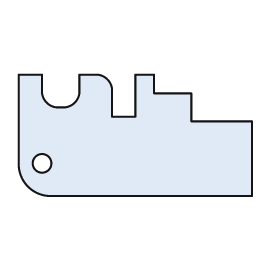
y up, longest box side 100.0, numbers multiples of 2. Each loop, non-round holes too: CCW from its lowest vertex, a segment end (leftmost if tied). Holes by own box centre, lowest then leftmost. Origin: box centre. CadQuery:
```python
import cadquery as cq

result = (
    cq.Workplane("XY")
    .moveTo(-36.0, -26.0)
    .lineTo(50.0, -26.0)
    .lineTo(50.0, 6.0)
    .lineTo(24.0, 6.0)
    .lineTo(24.0, 18.0)
    .lineTo(8.0, 18.0)
    .lineTo(8.0, 26.0)
    .lineTo(0.0, 26.0)
    .lineTo(0.0, 8.0)
    .lineTo(-10.0, 8.0)
    .lineTo(-10.0, 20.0)
    .threePointArc((-12.0, 24.0), (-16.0, 26.0))
    .lineTo(-24.0, 26.0)
    .lineTo(-24.0, 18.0)
    .threePointArc((-26.0, 14.0), (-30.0, 12.0))
    .lineTo(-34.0, 12.0)
    .threePointArc((-38.0, 14.0), (-40.0, 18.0))
    .lineTo(-40.0, 26.0)
    .lineTo(-50.0, 26.0)
    .lineTo(-50.0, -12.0)
    .threePointArc((-46.0, -22.0), (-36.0, -26.0))
    .close()
    .moveTo(-40.0, -12.0)
    .circle(4.0)
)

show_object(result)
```